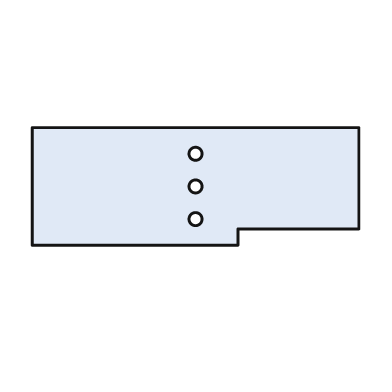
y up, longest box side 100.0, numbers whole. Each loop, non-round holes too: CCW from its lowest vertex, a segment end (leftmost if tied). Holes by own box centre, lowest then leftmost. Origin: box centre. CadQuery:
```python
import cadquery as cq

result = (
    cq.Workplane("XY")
    .moveTo(-50.0, -18.0)
    .lineTo(13.0, -18.0)
    .lineTo(13.0, -13.0)
    .lineTo(50.0, -13.0)
    .lineTo(50.0, 18.0)
    .lineTo(-50.0, 18.0)
    .close()
    .moveTo(0.0, -10.0)
    .circle(2.0)
    .moveTo(0.0, 0.0)
    .circle(2.0)
    .moveTo(0.0, 10.0)
    .circle(2.0)
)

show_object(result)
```